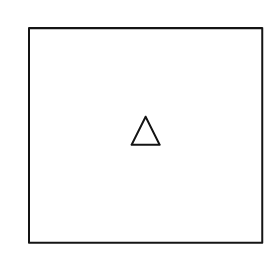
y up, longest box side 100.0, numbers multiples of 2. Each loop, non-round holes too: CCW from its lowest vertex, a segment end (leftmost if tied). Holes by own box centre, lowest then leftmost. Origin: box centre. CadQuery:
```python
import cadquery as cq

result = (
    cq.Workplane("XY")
    .moveTo(-50.0, -46.0)
    .lineTo(50.0, -46.0)
    .lineTo(50.0, 46.0)
    .lineTo(-50.0, 46.0)
    .close()
    .moveTo(-6.0, -4.0)
    .lineTo(6.0, -4.0)
    .lineTo(0.0, 8.0)
    .close()
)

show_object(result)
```